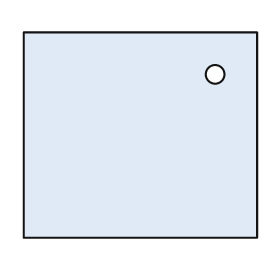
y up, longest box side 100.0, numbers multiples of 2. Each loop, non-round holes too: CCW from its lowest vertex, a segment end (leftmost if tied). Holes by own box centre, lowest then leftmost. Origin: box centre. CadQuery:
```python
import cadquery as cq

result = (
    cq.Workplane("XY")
    .moveTo(-50.0, -44.0)
    .lineTo(50.0, -44.0)
    .lineTo(50.0, 44.0)
    .lineTo(-50.0, 44.0)
    .close()
    .moveTo(32.0, 26.0)
    .circle(4.0)
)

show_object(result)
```